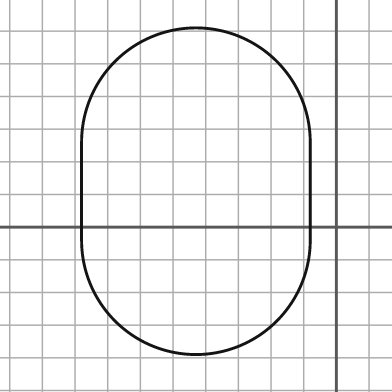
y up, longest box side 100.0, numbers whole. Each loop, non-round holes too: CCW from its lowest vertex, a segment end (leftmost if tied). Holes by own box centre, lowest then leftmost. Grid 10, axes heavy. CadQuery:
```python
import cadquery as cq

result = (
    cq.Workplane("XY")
    .moveTo(-78.0, -4.0)
    .threePointArc((-43.0, -39.0), (-8.0, -4.0))
    .lineTo(-8.0, 26.0)
    .threePointArc((-43.0, 61.0), (-78.0, 26.0))
    .close()
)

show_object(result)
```